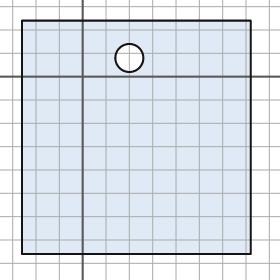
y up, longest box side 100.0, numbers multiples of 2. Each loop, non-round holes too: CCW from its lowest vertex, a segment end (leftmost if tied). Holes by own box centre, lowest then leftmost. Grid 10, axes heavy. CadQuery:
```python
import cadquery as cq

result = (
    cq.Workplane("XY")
    .moveTo(-26.0, -76.0)
    .lineTo(72.0, -76.0)
    .lineTo(72.0, 24.0)
    .lineTo(-26.0, 24.0)
    .close()
    .moveTo(20.0, 8.0)
    .circle(6.0)
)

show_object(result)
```